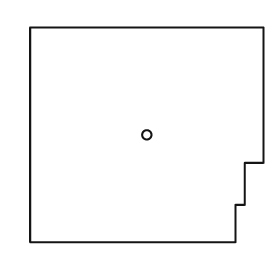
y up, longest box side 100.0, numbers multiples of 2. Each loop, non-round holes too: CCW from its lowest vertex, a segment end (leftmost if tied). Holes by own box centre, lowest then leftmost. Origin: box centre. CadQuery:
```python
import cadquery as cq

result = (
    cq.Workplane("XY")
    .moveTo(-50.0, -46.0)
    .lineTo(38.0, -46.0)
    .lineTo(38.0, -30.0)
    .lineTo(42.0, -30.0)
    .lineTo(42.0, -12.0)
    .lineTo(50.0, -12.0)
    .lineTo(50.0, 46.0)
    .lineTo(-50.0, 46.0)
    .close()
    .moveTo(0.0, 0.0)
    .circle(2.0)
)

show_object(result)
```